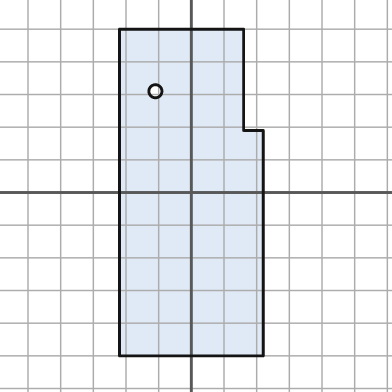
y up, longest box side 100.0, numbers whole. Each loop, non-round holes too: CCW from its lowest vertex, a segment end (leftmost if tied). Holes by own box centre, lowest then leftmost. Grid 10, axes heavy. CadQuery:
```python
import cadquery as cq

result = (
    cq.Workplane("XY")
    .moveTo(-22.0, -50.0)
    .lineTo(22.0, -50.0)
    .lineTo(22.0, 19.0)
    .lineTo(16.0, 19.0)
    .lineTo(16.0, 50.0)
    .lineTo(-22.0, 50.0)
    .close()
    .moveTo(-11.0, 31.0)
    .circle(2.0)
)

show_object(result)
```